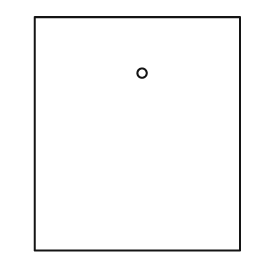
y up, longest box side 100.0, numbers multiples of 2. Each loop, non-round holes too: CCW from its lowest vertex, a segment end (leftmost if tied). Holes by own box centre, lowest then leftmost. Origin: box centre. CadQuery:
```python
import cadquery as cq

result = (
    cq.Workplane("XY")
    .moveTo(-44.0, -50.0)
    .lineTo(44.0, -50.0)
    .lineTo(44.0, 50.0)
    .lineTo(-44.0, 50.0)
    .close()
    .moveTo(2.0, 26.0)
    .circle(2.0)
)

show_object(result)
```